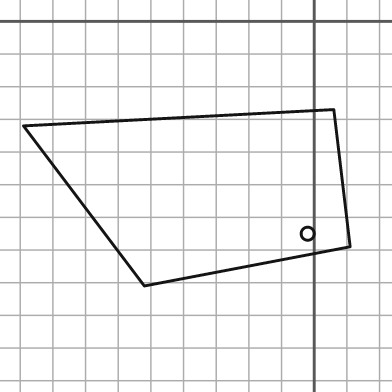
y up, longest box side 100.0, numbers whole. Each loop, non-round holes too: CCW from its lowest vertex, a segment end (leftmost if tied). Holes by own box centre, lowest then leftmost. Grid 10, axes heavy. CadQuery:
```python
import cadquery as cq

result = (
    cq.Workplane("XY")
    .moveTo(-52.0, -81.0)
    .lineTo(11.0, -69.0)
    .lineTo(6.0, -27.0)
    .lineTo(-89.0, -32.0)
    .close()
    .moveTo(-2.0, -65.0)
    .circle(2.0)
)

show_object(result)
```